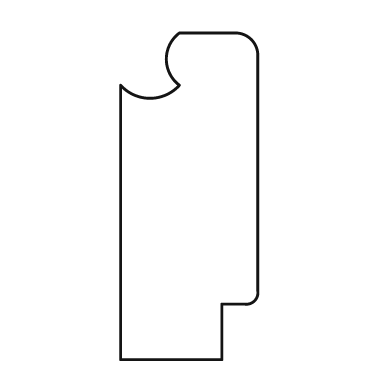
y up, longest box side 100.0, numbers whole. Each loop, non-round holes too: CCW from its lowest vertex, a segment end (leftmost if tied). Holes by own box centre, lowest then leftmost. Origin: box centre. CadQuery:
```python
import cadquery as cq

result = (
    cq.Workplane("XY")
    .moveTo(-21.0, -50.0)
    .lineTo(10.0, -50.0)
    .lineTo(10.0, -33.0)
    .lineTo(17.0, -33.0)
    .threePointArc((20.0, -32.0), (21.0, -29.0))
    .lineTo(21.0, 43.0)
    .threePointArc((19.0, 48.0), (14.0, 50.0))
    .lineTo(-3.0, 50.0)
    .threePointArc((-7.0, 42.0), (-3.0, 34.0))
    .threePointArc((-12.0, 30.0), (-21.0, 34.0))
    .close()
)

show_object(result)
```